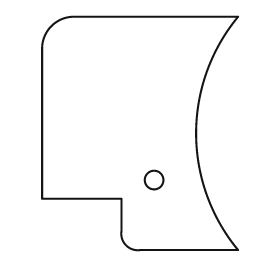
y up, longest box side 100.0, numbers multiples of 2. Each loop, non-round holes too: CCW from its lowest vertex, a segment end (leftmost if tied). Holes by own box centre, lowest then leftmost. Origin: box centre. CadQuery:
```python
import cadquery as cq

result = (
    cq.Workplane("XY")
    .moveTo(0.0, -50.0)
    .lineTo(42.0, -50.0)
    .threePointArc((24.0, 0.0), (42.0, 50.0))
    .lineTo(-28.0, 50.0)
    .threePointArc((-38.0, 46.0), (-42.0, 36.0))
    .lineTo(-42.0, -28.0)
    .lineTo(-8.0, -28.0)
    .lineTo(-8.0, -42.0)
    .threePointArc((-6.0, -48.0), (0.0, -50.0))
    .close()
    .moveTo(6.0, -20.0)
    .circle(4.0)
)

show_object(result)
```